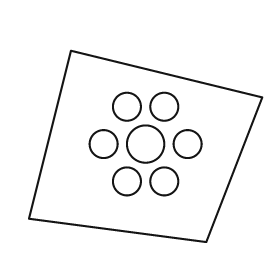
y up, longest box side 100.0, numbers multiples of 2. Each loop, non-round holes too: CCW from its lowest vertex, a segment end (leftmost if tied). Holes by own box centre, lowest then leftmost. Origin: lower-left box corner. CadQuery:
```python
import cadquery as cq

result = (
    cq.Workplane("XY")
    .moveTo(76.0, 0.0)
    .lineTo(100.0, 62.0)
    .lineTo(18.0, 82.0)
    .lineTo(0.0, 10.0)
    .close()
    .moveTo(42.0, 26.0)
    .circle(6.0)
    .moveTo(58.0, 26.0)
    .circle(6.0)
    .moveTo(32.0, 42.0)
    .circle(6.0)
    .moveTo(50.0, 42.0)
    .circle(8.0)
    .moveTo(68.0, 42.0)
    .circle(6.0)
    .moveTo(42.0, 58.0)
    .circle(6.0)
    .moveTo(58.0, 58.0)
    .circle(6.0)
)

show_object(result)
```